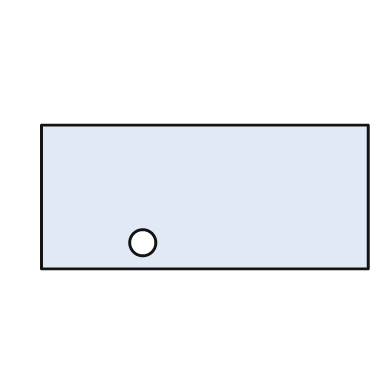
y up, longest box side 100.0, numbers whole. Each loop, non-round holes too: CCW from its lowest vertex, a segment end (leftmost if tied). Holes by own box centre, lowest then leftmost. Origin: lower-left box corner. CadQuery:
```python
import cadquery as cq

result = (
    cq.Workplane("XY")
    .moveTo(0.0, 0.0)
    .lineTo(100.0, 0.0)
    .lineTo(100.0, 44.0)
    .lineTo(0.0, 44.0)
    .close()
    .moveTo(31.0, 8.0)
    .circle(4.0)
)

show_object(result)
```